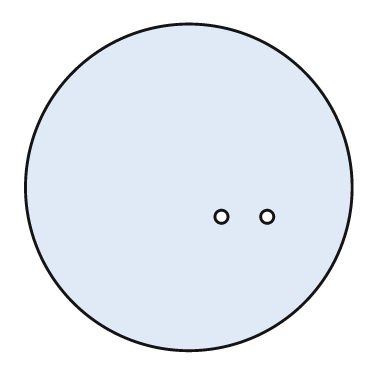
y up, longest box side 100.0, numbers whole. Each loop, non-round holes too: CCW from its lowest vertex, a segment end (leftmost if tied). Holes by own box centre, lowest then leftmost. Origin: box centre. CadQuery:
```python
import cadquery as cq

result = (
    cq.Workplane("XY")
    .moveTo(0.0, 0.0)
    .circle(50.0)
    .moveTo(10.0, -9.0)
    .circle(2.0)
    .moveTo(24.0, -9.0)
    .circle(2.0)
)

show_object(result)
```